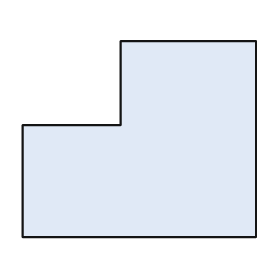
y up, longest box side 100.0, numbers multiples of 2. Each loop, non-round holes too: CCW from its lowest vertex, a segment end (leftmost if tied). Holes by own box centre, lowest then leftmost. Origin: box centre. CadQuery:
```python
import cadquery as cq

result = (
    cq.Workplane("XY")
    .moveTo(-50.0, -42.0)
    .lineTo(50.0, -42.0)
    .lineTo(50.0, 42.0)
    .lineTo(-8.0, 42.0)
    .lineTo(-8.0, 6.0)
    .lineTo(-50.0, 6.0)
    .close()
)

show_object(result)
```